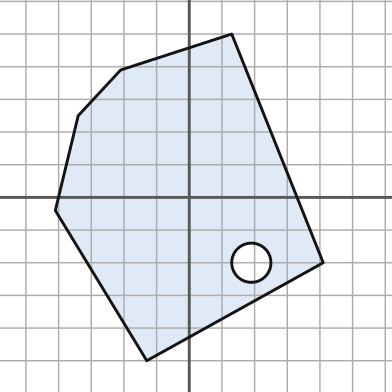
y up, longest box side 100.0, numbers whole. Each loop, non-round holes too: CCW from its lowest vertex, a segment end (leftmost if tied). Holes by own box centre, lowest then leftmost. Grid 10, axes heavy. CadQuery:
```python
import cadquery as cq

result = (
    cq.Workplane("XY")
    .moveTo(-13.0, -50.0)
    .lineTo(41.0, -20.0)
    .lineTo(13.0, 50.0)
    .lineTo(-21.0, 39.0)
    .lineTo(-34.0, 25.0)
    .lineTo(-41.0, -4.0)
    .close()
    .moveTo(19.0, -20.0)
    .circle(6.0)
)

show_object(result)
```